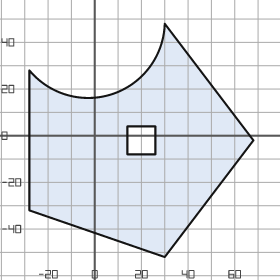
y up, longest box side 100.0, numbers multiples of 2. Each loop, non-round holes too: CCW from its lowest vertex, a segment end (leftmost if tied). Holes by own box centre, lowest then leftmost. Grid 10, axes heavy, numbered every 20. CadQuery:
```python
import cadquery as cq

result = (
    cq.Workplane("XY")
    .moveTo(30.0, -52.0)
    .lineTo(68.0, -2.0)
    .lineTo(30.0, 48.0)
    .threePointArc((8.0, 18.0), (-28.0, 28.0))
    .lineTo(-28.0, -32.0)
    .close()
    .moveTo(14.0, -8.0)
    .lineTo(26.0, -8.0)
    .lineTo(26.0, 4.0)
    .lineTo(14.0, 4.0)
    .close()
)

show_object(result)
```